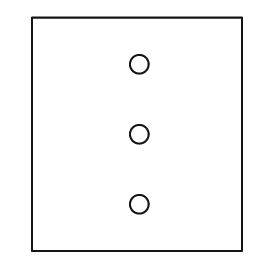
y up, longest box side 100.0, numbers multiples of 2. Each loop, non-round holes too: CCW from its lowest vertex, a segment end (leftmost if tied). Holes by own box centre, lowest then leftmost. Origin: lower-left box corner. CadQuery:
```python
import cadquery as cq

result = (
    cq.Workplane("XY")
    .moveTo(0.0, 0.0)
    .lineTo(90.0, 0.0)
    .lineTo(90.0, 100.0)
    .lineTo(0.0, 100.0)
    .close()
    .moveTo(46.0, 20.0)
    .circle(4.0)
    .moveTo(46.0, 50.0)
    .circle(4.0)
    .moveTo(46.0, 80.0)
    .circle(4.0)
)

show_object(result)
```